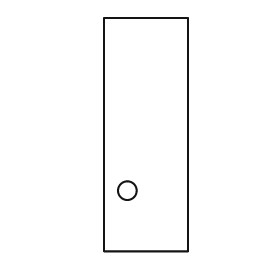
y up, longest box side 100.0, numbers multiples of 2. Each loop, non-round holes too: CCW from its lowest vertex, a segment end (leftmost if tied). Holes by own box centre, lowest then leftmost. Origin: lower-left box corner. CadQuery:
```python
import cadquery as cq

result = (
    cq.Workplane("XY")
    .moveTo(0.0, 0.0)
    .lineTo(36.0, 0.0)
    .lineTo(36.0, 100.0)
    .lineTo(0.0, 100.0)
    .close()
    .moveTo(10.0, 26.0)
    .circle(4.0)
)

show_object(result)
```